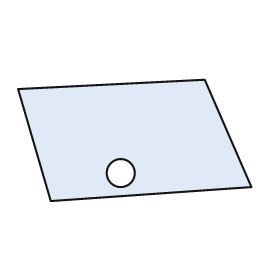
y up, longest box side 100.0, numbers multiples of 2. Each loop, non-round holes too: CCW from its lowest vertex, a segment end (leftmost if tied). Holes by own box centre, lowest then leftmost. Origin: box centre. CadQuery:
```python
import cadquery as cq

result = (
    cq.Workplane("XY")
    .moveTo(-36.0, -26.0)
    .lineTo(50.0, -20.0)
    .lineTo(30.0, 26.0)
    .lineTo(-50.0, 22.0)
    .close()
    .moveTo(-6.0, -14.0)
    .circle(6.0)
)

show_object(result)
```